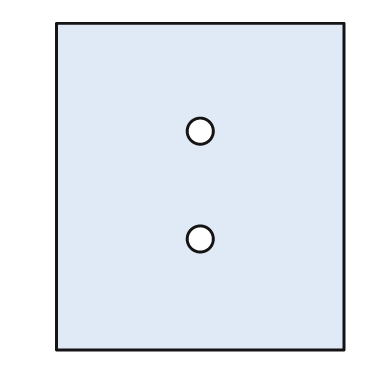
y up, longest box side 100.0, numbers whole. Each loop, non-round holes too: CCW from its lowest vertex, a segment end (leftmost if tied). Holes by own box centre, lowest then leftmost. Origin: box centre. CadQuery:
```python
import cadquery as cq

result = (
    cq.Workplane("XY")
    .moveTo(-44.0, -50.0)
    .lineTo(44.0, -50.0)
    .lineTo(44.0, 50.0)
    .lineTo(-44.0, 50.0)
    .close()
    .moveTo(0.0, -16.0)
    .circle(4.0)
    .moveTo(0.0, 17.0)
    .circle(4.0)
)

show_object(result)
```